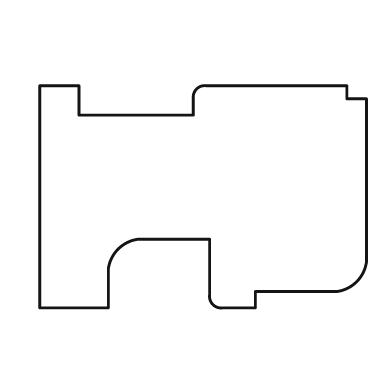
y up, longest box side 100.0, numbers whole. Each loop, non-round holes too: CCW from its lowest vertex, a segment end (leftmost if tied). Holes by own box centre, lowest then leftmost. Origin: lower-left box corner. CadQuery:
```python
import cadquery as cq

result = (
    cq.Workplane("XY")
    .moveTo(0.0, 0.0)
    .lineTo(21.0, 0.0)
    .lineTo(21.0, 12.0)
    .threePointArc((24.0, 18.0), (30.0, 21.0))
    .lineTo(52.0, 21.0)
    .lineTo(52.0, 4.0)
    .threePointArc((53.0, 1.0), (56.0, 0.0))
    .lineTo(66.0, 0.0)
    .lineTo(66.0, 5.0)
    .lineTo(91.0, 5.0)
    .threePointArc((97.0, 8.0), (100.0, 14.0))
    .lineTo(100.0, 64.0)
    .lineTo(94.0, 64.0)
    .lineTo(94.0, 68.0)
    .lineTo(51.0, 68.0)
    .threePointArc((48.0, 67.0), (47.0, 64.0))
    .lineTo(47.0, 59.0)
    .lineTo(12.0, 59.0)
    .lineTo(12.0, 68.0)
    .lineTo(0.0, 68.0)
    .close()
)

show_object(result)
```